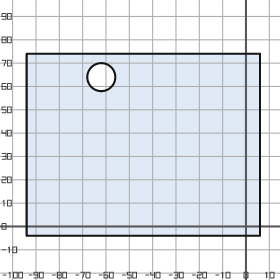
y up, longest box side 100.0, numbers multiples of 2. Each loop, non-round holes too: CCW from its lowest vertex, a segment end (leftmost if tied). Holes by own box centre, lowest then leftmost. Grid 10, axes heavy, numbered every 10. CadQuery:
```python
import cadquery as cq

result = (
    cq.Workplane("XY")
    .moveTo(-94.0, -4.0)
    .lineTo(6.0, -4.0)
    .lineTo(6.0, 74.0)
    .lineTo(-94.0, 74.0)
    .close()
    .moveTo(-62.0, 64.0)
    .circle(6.0)
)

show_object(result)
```